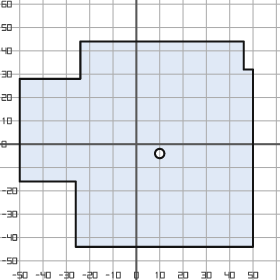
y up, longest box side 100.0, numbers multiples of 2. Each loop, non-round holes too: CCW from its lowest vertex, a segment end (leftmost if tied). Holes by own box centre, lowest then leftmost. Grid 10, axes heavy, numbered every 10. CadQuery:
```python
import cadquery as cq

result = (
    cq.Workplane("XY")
    .moveTo(-26.0, -44.0)
    .lineTo(50.0, -44.0)
    .lineTo(50.0, 32.0)
    .lineTo(46.0, 32.0)
    .lineTo(46.0, 44.0)
    .lineTo(-24.0, 44.0)
    .lineTo(-24.0, 28.0)
    .lineTo(-50.0, 28.0)
    .lineTo(-50.0, -16.0)
    .lineTo(-26.0, -16.0)
    .close()
    .moveTo(10.0, -4.0)
    .circle(2.0)
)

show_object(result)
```